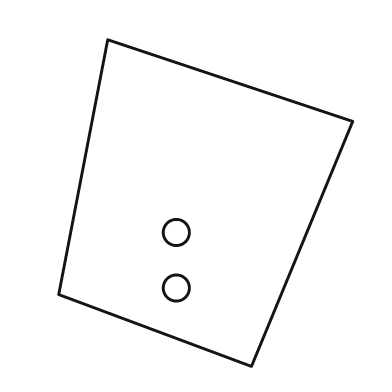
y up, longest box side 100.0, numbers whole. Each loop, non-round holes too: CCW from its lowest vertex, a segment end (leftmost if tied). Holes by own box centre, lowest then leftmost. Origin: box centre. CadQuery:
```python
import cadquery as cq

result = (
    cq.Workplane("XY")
    .moveTo(14.0, -50.0)
    .lineTo(45.0, 25.0)
    .lineTo(-30.0, 50.0)
    .lineTo(-45.0, -28.0)
    .close()
    .moveTo(-9.0, -26.0)
    .circle(4.0)
    .moveTo(-9.0, -9.0)
    .circle(4.0)
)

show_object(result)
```